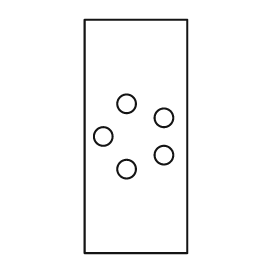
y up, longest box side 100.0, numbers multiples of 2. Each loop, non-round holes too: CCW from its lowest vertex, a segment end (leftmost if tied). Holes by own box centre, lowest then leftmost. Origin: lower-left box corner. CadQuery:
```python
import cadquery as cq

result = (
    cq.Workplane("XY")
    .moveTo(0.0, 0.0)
    .lineTo(44.0, 0.0)
    .lineTo(44.0, 100.0)
    .lineTo(0.0, 100.0)
    .close()
    .moveTo(18.0, 36.0)
    .circle(4.0)
    .moveTo(34.0, 42.0)
    .circle(4.0)
    .moveTo(8.0, 50.0)
    .circle(4.0)
    .moveTo(34.0, 58.0)
    .circle(4.0)
    .moveTo(18.0, 64.0)
    .circle(4.0)
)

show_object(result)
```